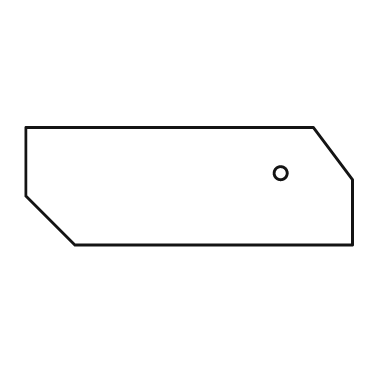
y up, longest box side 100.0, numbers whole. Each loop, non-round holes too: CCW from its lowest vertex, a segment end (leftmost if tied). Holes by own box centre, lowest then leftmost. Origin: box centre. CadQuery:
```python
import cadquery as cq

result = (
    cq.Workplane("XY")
    .moveTo(-35.0, -18.0)
    .lineTo(50.0, -18.0)
    .lineTo(50.0, 2.0)
    .lineTo(38.0, 18.0)
    .lineTo(-50.0, 18.0)
    .lineTo(-50.0, -3.0)
    .close()
    .moveTo(28.0, 4.0)
    .circle(2.0)
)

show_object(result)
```